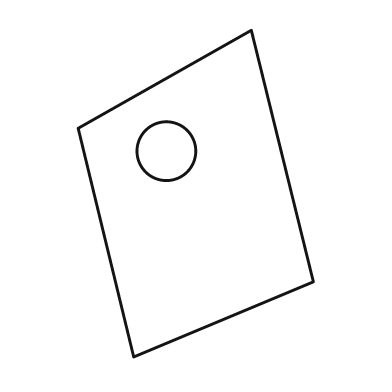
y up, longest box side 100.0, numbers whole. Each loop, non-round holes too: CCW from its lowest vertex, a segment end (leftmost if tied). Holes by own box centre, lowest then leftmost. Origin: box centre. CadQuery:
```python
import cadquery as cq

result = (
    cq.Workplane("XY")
    .moveTo(-19.0, -50.0)
    .lineTo(36.0, -27.0)
    .lineTo(17.0, 50.0)
    .lineTo(-36.0, 20.0)
    .close()
    .moveTo(-9.0, 13.0)
    .circle(9.0)
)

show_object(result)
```